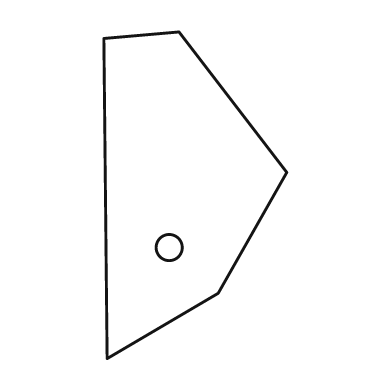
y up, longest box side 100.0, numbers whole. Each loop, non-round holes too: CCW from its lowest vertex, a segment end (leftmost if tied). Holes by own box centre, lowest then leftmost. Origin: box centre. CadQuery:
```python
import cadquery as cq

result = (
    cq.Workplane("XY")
    .moveTo(-27.0, -50.0)
    .lineTo(7.0, -30.0)
    .lineTo(28.0, 7.0)
    .lineTo(-5.0, 50.0)
    .lineTo(-28.0, 48.0)
    .close()
    .moveTo(-8.0, -16.0)
    .circle(4.0)
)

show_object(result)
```